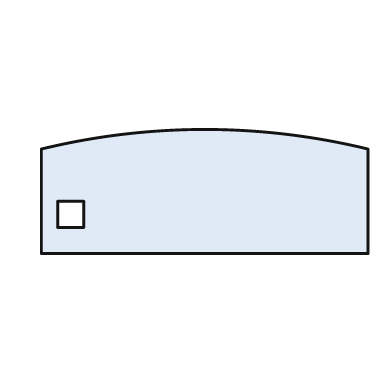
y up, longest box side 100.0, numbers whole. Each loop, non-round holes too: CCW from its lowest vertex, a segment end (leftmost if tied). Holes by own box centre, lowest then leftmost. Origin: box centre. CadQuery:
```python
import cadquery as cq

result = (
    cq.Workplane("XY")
    .moveTo(-50.0, -19.0)
    .lineTo(50.0, -19.0)
    .lineTo(50.0, 13.0)
    .threePointArc((0.0, 19.0), (-50.0, 13.0))
    .close()
    .moveTo(-45.0, -11.0)
    .lineTo(-37.0, -11.0)
    .lineTo(-37.0, -3.0)
    .lineTo(-45.0, -3.0)
    .close()
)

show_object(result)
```